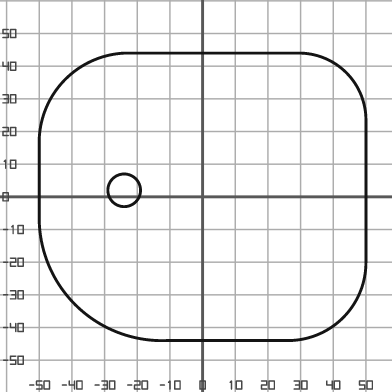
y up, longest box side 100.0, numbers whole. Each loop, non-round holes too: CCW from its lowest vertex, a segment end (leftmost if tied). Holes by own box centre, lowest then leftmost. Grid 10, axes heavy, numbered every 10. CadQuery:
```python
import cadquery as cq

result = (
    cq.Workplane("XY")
    .moveTo(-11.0, -44.0)
    .lineTo(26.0, -44.0)
    .threePointArc((43.0, -37.0), (50.0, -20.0))
    .lineTo(50.0, 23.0)
    .threePointArc((44.0, 38.0), (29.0, 44.0))
    .lineTo(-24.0, 44.0)
    .threePointArc((-42.0, 36.0), (-50.0, 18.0))
    .lineTo(-50.0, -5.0)
    .threePointArc((-39.0, -33.0), (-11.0, -44.0))
    .close()
    .moveTo(-24.0, 2.0)
    .circle(5.0)
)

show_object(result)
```